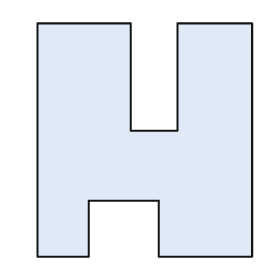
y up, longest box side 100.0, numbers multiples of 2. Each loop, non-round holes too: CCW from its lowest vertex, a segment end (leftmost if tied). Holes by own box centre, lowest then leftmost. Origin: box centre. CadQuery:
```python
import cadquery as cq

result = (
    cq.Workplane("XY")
    .moveTo(-46.0, -50.0)
    .lineTo(-24.0, -50.0)
    .lineTo(-24.0, -26.0)
    .lineTo(6.0, -26.0)
    .lineTo(6.0, -50.0)
    .lineTo(46.0, -50.0)
    .lineTo(46.0, 50.0)
    .lineTo(14.0, 50.0)
    .lineTo(14.0, 4.0)
    .lineTo(-6.0, 4.0)
    .lineTo(-6.0, 50.0)
    .lineTo(-46.0, 50.0)
    .close()
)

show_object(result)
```